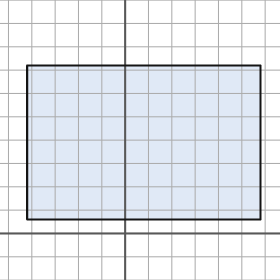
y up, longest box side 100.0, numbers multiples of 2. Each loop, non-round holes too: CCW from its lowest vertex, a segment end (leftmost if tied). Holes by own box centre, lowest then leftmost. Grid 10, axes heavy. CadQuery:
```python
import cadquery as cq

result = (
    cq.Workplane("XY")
    .moveTo(-42.0, 6.0)
    .lineTo(58.0, 6.0)
    .lineTo(58.0, 72.0)
    .lineTo(-42.0, 72.0)
    .close()
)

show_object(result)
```